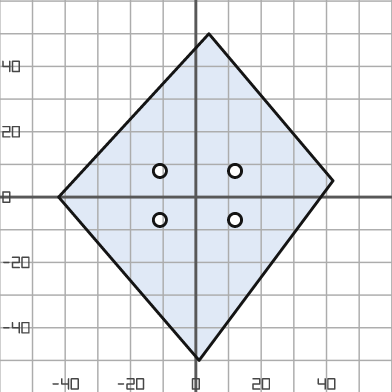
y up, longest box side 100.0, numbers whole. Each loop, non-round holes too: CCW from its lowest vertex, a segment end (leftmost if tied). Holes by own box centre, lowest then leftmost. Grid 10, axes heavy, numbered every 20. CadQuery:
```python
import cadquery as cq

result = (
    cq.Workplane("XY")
    .moveTo(1.0, -50.0)
    .lineTo(42.0, 5.0)
    .lineTo(4.0, 50.0)
    .lineTo(-42.0, 0.0)
    .close()
    .moveTo(-11.0, -7.0)
    .circle(2.0)
    .moveTo(12.0, -7.0)
    .circle(2.0)
    .moveTo(-11.0, 8.0)
    .circle(2.0)
    .moveTo(12.0, 8.0)
    .circle(2.0)
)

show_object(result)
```